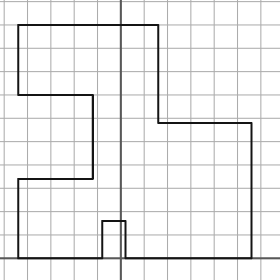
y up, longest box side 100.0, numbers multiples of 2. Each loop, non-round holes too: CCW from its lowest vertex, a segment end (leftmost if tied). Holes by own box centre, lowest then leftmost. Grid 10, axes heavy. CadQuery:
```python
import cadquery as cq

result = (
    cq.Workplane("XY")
    .moveTo(-44.0, 0.0)
    .lineTo(-8.0, 0.0)
    .lineTo(-8.0, 16.0)
    .lineTo(2.0, 16.0)
    .lineTo(2.0, 0.0)
    .lineTo(56.0, 0.0)
    .lineTo(56.0, 58.0)
    .lineTo(16.0, 58.0)
    .lineTo(16.0, 100.0)
    .lineTo(-44.0, 100.0)
    .lineTo(-44.0, 70.0)
    .lineTo(-12.0, 70.0)
    .lineTo(-12.0, 34.0)
    .lineTo(-44.0, 34.0)
    .close()
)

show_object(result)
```